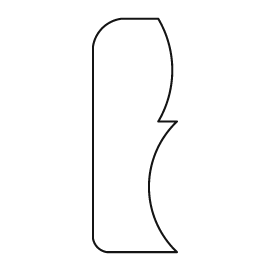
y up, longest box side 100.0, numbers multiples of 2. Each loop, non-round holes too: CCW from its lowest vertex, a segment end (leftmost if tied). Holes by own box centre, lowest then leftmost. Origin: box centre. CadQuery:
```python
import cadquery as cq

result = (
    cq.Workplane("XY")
    .moveTo(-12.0, -50.0)
    .lineTo(18.0, -50.0)
    .threePointArc((6.0, -22.0), (18.0, 6.0))
    .lineTo(10.0, 6.0)
    .threePointArc((16.0, 28.0), (10.0, 50.0))
    .lineTo(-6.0, 50.0)
    .threePointArc((-14.0, 46.0), (-18.0, 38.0))
    .lineTo(-18.0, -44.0)
    .threePointArc((-16.0, -48.0), (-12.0, -50.0))
    .close()
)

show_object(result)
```